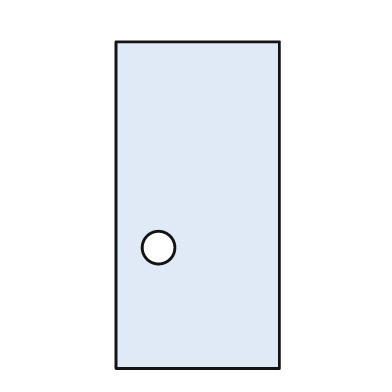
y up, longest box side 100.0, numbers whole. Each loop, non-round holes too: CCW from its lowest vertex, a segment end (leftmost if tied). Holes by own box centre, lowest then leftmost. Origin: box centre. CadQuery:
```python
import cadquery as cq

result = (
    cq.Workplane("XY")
    .moveTo(-25.0, -50.0)
    .lineTo(25.0, -50.0)
    .lineTo(25.0, 50.0)
    .lineTo(-25.0, 50.0)
    .close()
    .moveTo(-12.0, -13.0)
    .circle(5.0)
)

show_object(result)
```